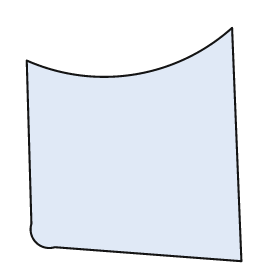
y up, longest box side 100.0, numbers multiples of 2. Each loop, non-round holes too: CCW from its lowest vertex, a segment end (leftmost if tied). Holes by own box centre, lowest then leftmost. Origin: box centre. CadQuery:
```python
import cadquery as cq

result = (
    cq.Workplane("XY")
    .moveTo(46.0, -50.0)
    .lineTo(42.0, 50.0)
    .threePointArc((0.0, 30.0), (-46.0, 36.0))
    .lineTo(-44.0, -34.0)
    .threePointArc((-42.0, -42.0), (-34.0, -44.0))
    .close()
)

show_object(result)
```